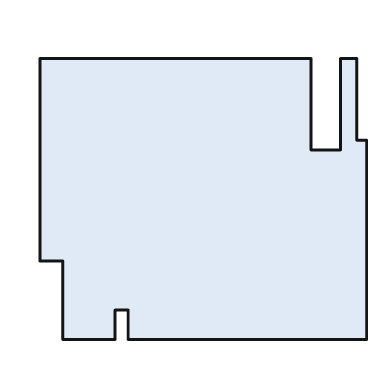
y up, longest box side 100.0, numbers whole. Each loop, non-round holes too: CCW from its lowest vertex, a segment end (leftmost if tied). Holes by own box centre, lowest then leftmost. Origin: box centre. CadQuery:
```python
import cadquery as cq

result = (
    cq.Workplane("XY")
    .moveTo(-43.0, -43.0)
    .lineTo(-27.0, -43.0)
    .lineTo(-27.0, -34.0)
    .lineTo(-23.0, -34.0)
    .lineTo(-23.0, -43.0)
    .lineTo(50.0, -43.0)
    .lineTo(50.0, 18.0)
    .lineTo(47.0, 18.0)
    .lineTo(47.0, 43.0)
    .lineTo(42.0, 43.0)
    .lineTo(42.0, 15.0)
    .lineTo(33.0, 15.0)
    .lineTo(33.0, 43.0)
    .lineTo(-50.0, 43.0)
    .lineTo(-50.0, -19.0)
    .lineTo(-43.0, -19.0)
    .close()
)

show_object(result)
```